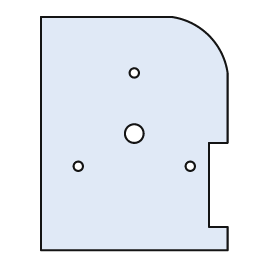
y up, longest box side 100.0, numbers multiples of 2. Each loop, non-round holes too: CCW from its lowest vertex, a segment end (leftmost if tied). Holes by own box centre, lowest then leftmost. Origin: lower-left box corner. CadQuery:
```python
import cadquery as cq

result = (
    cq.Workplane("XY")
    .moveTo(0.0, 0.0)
    .lineTo(80.0, 0.0)
    .lineTo(80.0, 10.0)
    .lineTo(72.0, 10.0)
    .lineTo(72.0, 46.0)
    .lineTo(80.0, 46.0)
    .lineTo(80.0, 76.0)
    .threePointArc((72.0, 92.0), (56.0, 100.0))
    .lineTo(0.0, 100.0)
    .close()
    .moveTo(16.0, 36.0)
    .circle(2.0)
    .moveTo(64.0, 36.0)
    .circle(2.0)
    .moveTo(40.0, 50.0)
    .circle(4.0)
    .moveTo(40.0, 76.0)
    .circle(2.0)
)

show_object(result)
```